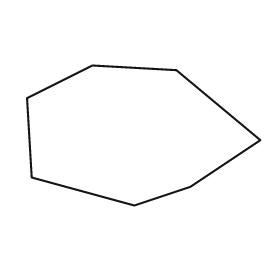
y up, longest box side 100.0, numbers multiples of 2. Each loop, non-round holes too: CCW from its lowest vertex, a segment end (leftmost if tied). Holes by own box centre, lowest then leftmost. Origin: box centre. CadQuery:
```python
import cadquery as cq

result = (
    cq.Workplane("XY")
    .moveTo(-4.0, -30.0)
    .lineTo(20.0, -22.0)
    .lineTo(50.0, -2.0)
    .lineTo(14.0, 28.0)
    .lineTo(-22.0, 30.0)
    .lineTo(-50.0, 16.0)
    .lineTo(-48.0, -18.0)
    .close()
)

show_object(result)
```